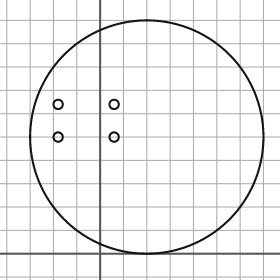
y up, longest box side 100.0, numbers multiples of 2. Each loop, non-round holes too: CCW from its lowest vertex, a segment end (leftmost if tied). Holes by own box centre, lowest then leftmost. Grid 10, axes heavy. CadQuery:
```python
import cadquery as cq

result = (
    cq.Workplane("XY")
    .moveTo(20.0, 50.0)
    .circle(50.0)
    .moveTo(-18.0, 50.0)
    .circle(2.0)
    .moveTo(6.0, 50.0)
    .circle(2.0)
    .moveTo(-18.0, 64.0)
    .circle(2.0)
    .moveTo(6.0, 64.0)
    .circle(2.0)
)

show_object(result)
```